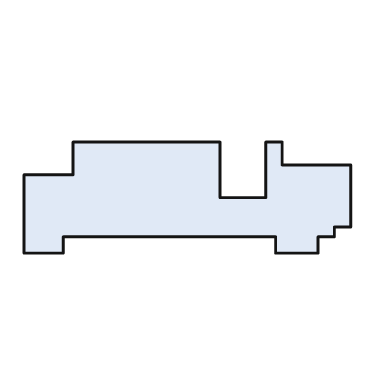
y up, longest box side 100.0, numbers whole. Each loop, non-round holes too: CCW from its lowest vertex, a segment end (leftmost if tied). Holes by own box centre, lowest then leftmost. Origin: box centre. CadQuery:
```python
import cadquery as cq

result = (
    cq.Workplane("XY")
    .moveTo(-50.0, -17.0)
    .lineTo(-38.0, -17.0)
    .lineTo(-38.0, -12.0)
    .lineTo(27.0, -12.0)
    .lineTo(27.0, -17.0)
    .lineTo(40.0, -17.0)
    .lineTo(40.0, -12.0)
    .lineTo(45.0, -12.0)
    .lineTo(45.0, -9.0)
    .lineTo(50.0, -9.0)
    .lineTo(50.0, 10.0)
    .lineTo(29.0, 10.0)
    .lineTo(29.0, 17.0)
    .lineTo(24.0, 17.0)
    .lineTo(24.0, 0.0)
    .lineTo(10.0, 0.0)
    .lineTo(10.0, 17.0)
    .lineTo(-35.0, 17.0)
    .lineTo(-35.0, 7.0)
    .lineTo(-50.0, 7.0)
    .close()
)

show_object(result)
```